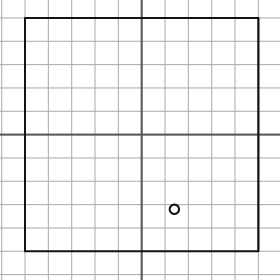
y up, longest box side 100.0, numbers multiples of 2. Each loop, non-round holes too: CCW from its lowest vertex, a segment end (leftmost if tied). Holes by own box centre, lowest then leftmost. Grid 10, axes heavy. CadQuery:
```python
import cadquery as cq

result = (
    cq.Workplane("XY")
    .moveTo(-50.0, -50.0)
    .lineTo(50.0, -50.0)
    .lineTo(50.0, 50.0)
    .lineTo(-50.0, 50.0)
    .close()
    .moveTo(14.0, -32.0)
    .circle(2.0)
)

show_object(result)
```